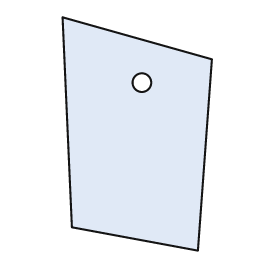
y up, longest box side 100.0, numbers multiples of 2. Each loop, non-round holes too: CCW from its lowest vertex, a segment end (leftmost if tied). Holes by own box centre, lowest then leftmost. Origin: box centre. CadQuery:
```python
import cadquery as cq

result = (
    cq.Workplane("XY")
    .moveTo(26.0, -50.0)
    .lineTo(32.0, 32.0)
    .lineTo(-32.0, 50.0)
    .lineTo(-28.0, -40.0)
    .close()
    .moveTo(2.0, 22.0)
    .circle(4.0)
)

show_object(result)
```